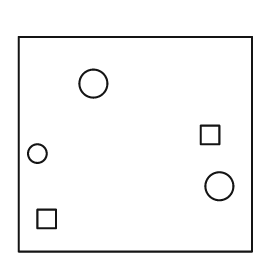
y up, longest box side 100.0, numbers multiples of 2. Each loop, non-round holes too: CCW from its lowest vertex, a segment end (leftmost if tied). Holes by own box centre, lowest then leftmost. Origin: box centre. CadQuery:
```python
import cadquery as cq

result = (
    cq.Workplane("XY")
    .moveTo(-50.0, -46.0)
    .lineTo(50.0, -46.0)
    .lineTo(50.0, 46.0)
    .lineTo(-50.0, 46.0)
    .close()
    .moveTo(-42.0, -36.0)
    .lineTo(-34.0, -36.0)
    .lineTo(-34.0, -28.0)
    .lineTo(-42.0, -28.0)
    .close()
    .moveTo(36.0, -18.0)
    .circle(6.0)
    .moveTo(-42.0, -4.0)
    .circle(4.0)
    .moveTo(28.0, 0.0)
    .lineTo(36.0, 0.0)
    .lineTo(36.0, 8.0)
    .lineTo(28.0, 8.0)
    .close()
    .moveTo(-18.0, 26.0)
    .circle(6.0)
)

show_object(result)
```